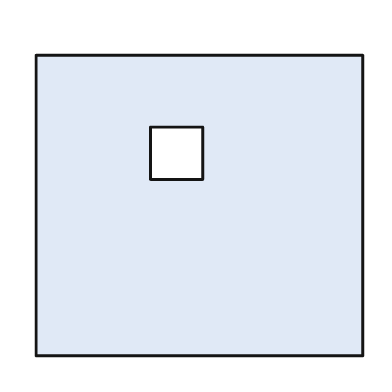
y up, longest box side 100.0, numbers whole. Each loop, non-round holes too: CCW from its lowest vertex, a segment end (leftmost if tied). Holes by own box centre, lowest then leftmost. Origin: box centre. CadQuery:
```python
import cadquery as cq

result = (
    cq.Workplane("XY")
    .moveTo(-50.0, -46.0)
    .lineTo(50.0, -46.0)
    .lineTo(50.0, 46.0)
    .lineTo(-50.0, 46.0)
    .close()
    .moveTo(-15.0, 8.0)
    .lineTo(1.0, 8.0)
    .lineTo(1.0, 24.0)
    .lineTo(-15.0, 24.0)
    .close()
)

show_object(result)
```